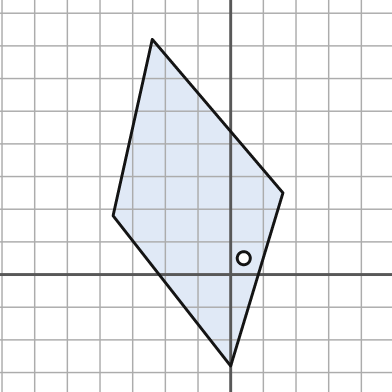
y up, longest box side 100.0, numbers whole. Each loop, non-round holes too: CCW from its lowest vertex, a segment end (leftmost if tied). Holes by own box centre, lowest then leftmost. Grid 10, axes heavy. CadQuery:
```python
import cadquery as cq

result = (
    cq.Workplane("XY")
    .moveTo(0.0, -28.0)
    .lineTo(16.0, 25.0)
    .lineTo(-24.0, 72.0)
    .lineTo(-36.0, 18.0)
    .close()
    .moveTo(4.0, 5.0)
    .circle(2.0)
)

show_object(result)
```